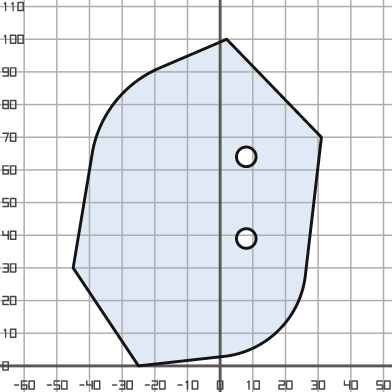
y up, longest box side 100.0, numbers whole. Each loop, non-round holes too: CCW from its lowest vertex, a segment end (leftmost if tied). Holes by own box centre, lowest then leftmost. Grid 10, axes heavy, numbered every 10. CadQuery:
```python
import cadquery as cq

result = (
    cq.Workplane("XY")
    .moveTo(-25.0, 0.0)
    .lineTo(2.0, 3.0)
    .threePointArc((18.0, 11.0), (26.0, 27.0))
    .lineTo(31.0, 70.0)
    .lineTo(2.0, 100.0)
    .lineTo(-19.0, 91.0)
    .threePointArc((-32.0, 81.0), (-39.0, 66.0))
    .lineTo(-45.0, 30.0)
    .close()
    .moveTo(8.0, 39.0)
    .circle(3.0)
    .moveTo(8.0, 64.0)
    .circle(3.0)
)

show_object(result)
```